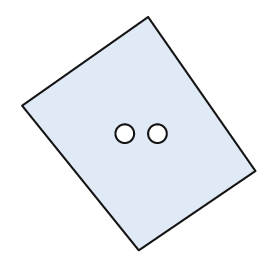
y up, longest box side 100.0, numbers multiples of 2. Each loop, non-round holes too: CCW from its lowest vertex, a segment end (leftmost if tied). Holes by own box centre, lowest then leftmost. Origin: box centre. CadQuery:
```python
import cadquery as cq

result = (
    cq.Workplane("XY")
    .moveTo(0.0, -50.0)
    .lineTo(50.0, -16.0)
    .lineTo(4.0, 50.0)
    .lineTo(-50.0, 12.0)
    .close()
    .moveTo(-6.0, 0.0)
    .circle(4.0)
    .moveTo(8.0, 0.0)
    .circle(4.0)
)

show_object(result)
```